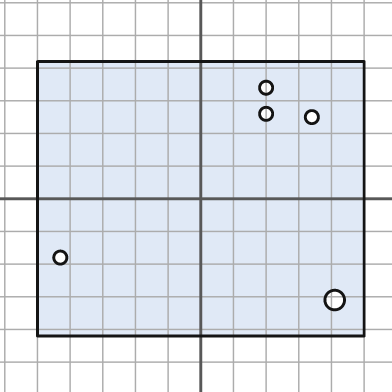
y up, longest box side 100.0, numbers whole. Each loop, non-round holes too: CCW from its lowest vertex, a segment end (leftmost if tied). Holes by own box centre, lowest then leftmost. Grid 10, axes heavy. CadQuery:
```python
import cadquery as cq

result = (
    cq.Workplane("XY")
    .moveTo(-50.0, -42.0)
    .lineTo(50.0, -42.0)
    .lineTo(50.0, 42.0)
    .lineTo(-50.0, 42.0)
    .close()
    .moveTo(41.0, -31.0)
    .circle(3.0)
    .moveTo(-43.0, -18.0)
    .circle(2.0)
    .moveTo(34.0, 25.0)
    .circle(2.0)
    .moveTo(20.0, 26.0)
    .circle(2.0)
    .moveTo(20.0, 34.0)
    .circle(2.0)
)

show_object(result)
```